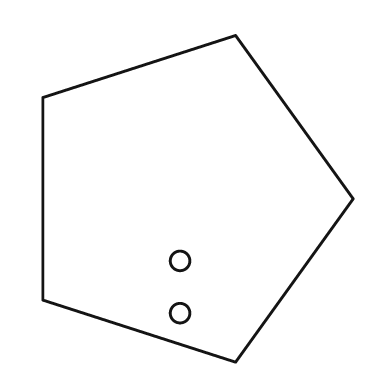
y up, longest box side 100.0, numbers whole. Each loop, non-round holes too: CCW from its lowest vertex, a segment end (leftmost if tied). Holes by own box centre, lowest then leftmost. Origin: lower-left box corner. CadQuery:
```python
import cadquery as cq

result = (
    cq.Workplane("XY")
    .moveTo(59.0, 0.0)
    .lineTo(95.0, 50.0)
    .lineTo(59.0, 100.0)
    .lineTo(0.0, 81.0)
    .lineTo(0.0, 19.0)
    .close()
    .moveTo(42.0, 15.0)
    .circle(3.0)
    .moveTo(42.0, 31.0)
    .circle(3.0)
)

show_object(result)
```